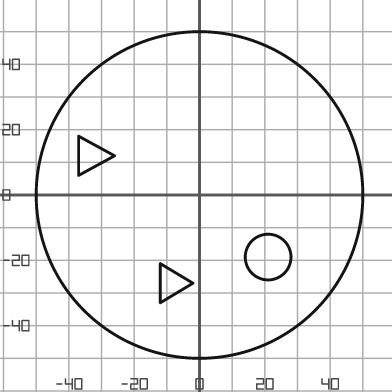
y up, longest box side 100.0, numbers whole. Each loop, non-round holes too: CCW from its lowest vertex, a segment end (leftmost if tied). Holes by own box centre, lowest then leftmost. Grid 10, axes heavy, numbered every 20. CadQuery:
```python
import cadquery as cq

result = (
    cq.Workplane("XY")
    .moveTo(0.0, 0.0)
    .circle(50.0)
    .moveTo(-12.0, -33.0)
    .lineTo(-2.0, -27.0)
    .lineTo(-12.0, -21.0)
    .close()
    .moveTo(21.0, -19.0)
    .circle(7.0)
    .moveTo(-37.0, 6.0)
    .lineTo(-26.0, 12.0)
    .lineTo(-37.0, 18.0)
    .close()
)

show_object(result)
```